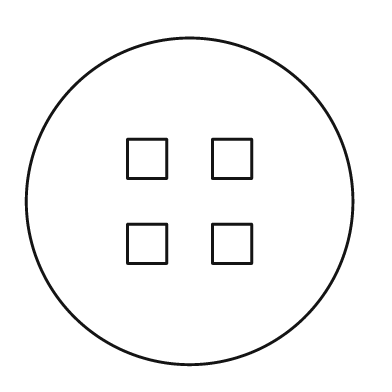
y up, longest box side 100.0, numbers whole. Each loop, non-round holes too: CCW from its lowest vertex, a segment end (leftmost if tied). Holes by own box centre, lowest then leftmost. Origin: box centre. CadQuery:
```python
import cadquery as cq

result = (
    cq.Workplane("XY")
    .moveTo(0.0, 0.0)
    .circle(50.0)
    .moveTo(-19.0, -19.0)
    .lineTo(-7.0, -19.0)
    .lineTo(-7.0, -7.0)
    .lineTo(-19.0, -7.0)
    .close()
    .moveTo(7.0, -19.0)
    .lineTo(19.0, -19.0)
    .lineTo(19.0, -7.0)
    .lineTo(7.0, -7.0)
    .close()
    .moveTo(-19.0, 7.0)
    .lineTo(-7.0, 7.0)
    .lineTo(-7.0, 19.0)
    .lineTo(-19.0, 19.0)
    .close()
    .moveTo(7.0, 7.0)
    .lineTo(19.0, 7.0)
    .lineTo(19.0, 19.0)
    .lineTo(7.0, 19.0)
    .close()
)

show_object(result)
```